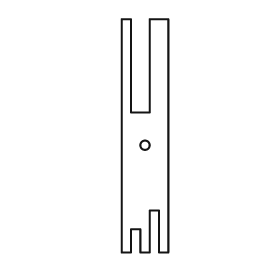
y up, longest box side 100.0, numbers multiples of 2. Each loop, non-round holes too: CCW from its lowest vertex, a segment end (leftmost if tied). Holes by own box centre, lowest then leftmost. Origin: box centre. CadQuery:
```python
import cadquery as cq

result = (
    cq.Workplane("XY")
    .moveTo(-10.0, -50.0)
    .lineTo(-6.0, -50.0)
    .lineTo(-6.0, -40.0)
    .lineTo(-2.0, -40.0)
    .lineTo(-2.0, -50.0)
    .lineTo(2.0, -50.0)
    .lineTo(2.0, -32.0)
    .lineTo(6.0, -32.0)
    .lineTo(6.0, -50.0)
    .lineTo(10.0, -50.0)
    .lineTo(10.0, 50.0)
    .lineTo(2.0, 50.0)
    .lineTo(2.0, 10.0)
    .lineTo(-6.0, 10.0)
    .lineTo(-6.0, 50.0)
    .lineTo(-10.0, 50.0)
    .close()
    .moveTo(0.0, -4.0)
    .circle(2.0)
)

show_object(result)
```